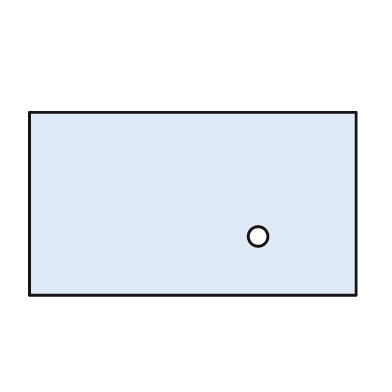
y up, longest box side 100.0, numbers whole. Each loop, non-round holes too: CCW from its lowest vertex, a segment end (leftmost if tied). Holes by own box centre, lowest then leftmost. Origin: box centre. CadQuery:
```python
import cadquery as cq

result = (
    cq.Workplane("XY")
    .moveTo(-50.0, -28.0)
    .lineTo(50.0, -28.0)
    .lineTo(50.0, 28.0)
    .lineTo(-50.0, 28.0)
    .close()
    .moveTo(20.0, -10.0)
    .circle(3.0)
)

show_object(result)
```